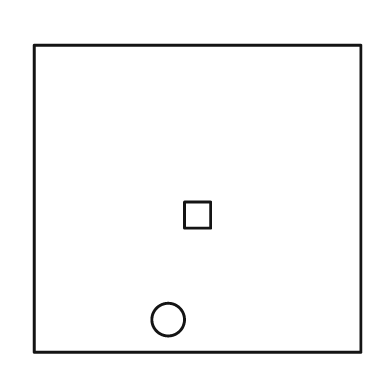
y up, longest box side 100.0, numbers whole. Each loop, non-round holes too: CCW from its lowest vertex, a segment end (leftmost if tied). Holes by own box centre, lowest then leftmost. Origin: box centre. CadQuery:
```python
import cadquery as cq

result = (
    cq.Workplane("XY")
    .moveTo(-50.0, -47.0)
    .lineTo(50.0, -47.0)
    .lineTo(50.0, 47.0)
    .lineTo(-50.0, 47.0)
    .close()
    .moveTo(-9.0, -37.0)
    .circle(5.0)
    .moveTo(-4.0, -9.0)
    .lineTo(4.0, -9.0)
    .lineTo(4.0, -1.0)
    .lineTo(-4.0, -1.0)
    .close()
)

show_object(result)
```